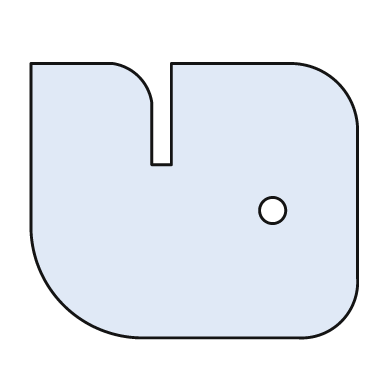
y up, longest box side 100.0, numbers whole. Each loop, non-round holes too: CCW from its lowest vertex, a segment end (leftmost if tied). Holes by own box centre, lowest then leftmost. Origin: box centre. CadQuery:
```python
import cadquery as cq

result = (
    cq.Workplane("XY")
    .moveTo(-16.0, -42.0)
    .lineTo(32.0, -42.0)
    .threePointArc((45.0, -37.0), (50.0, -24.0))
    .lineTo(50.0, 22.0)
    .threePointArc((44.0, 36.0), (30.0, 42.0))
    .lineTo(-7.0, 42.0)
    .lineTo(-7.0, 11.0)
    .lineTo(-13.0, 11.0)
    .lineTo(-13.0, 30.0)
    .threePointArc((-17.0, 38.0), (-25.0, 42.0))
    .lineTo(-50.0, 42.0)
    .lineTo(-50.0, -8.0)
    .threePointArc((-40.0, -32.0), (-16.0, -42.0))
    .close()
    .moveTo(24.0, -3.0)
    .circle(4.0)
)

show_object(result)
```